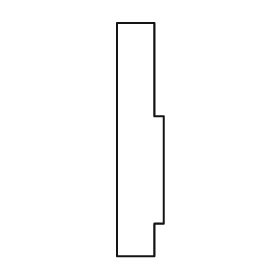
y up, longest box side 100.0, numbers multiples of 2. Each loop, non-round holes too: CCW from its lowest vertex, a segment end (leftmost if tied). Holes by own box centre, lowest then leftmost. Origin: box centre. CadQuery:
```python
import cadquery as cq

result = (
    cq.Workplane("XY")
    .moveTo(-10.0, -50.0)
    .lineTo(6.0, -50.0)
    .lineTo(6.0, -36.0)
    .lineTo(10.0, -36.0)
    .lineTo(10.0, 10.0)
    .lineTo(6.0, 10.0)
    .lineTo(6.0, 50.0)
    .lineTo(-10.0, 50.0)
    .close()
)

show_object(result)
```